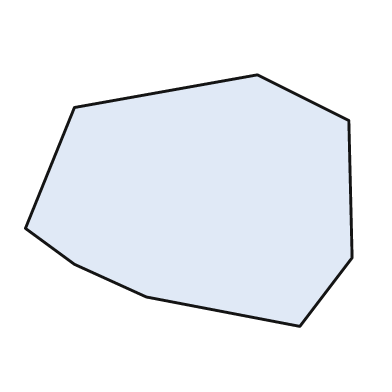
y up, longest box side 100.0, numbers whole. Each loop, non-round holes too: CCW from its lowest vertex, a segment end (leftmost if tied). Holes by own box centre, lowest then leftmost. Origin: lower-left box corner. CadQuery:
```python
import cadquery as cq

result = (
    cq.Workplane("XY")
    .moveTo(84.0, 0.0)
    .lineTo(100.0, 21.0)
    .lineTo(99.0, 63.0)
    .lineTo(71.0, 77.0)
    .lineTo(15.0, 67.0)
    .lineTo(0.0, 30.0)
    .lineTo(15.0, 19.0)
    .lineTo(37.0, 9.0)
    .close()
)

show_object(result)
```